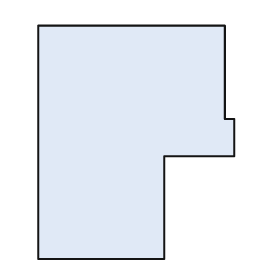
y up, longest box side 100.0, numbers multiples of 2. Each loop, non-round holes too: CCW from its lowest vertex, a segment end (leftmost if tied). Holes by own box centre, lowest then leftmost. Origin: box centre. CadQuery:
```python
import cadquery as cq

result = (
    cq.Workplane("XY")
    .moveTo(-42.0, -50.0)
    .lineTo(12.0, -50.0)
    .lineTo(12.0, -6.0)
    .lineTo(42.0, -6.0)
    .lineTo(42.0, 10.0)
    .lineTo(38.0, 10.0)
    .lineTo(38.0, 50.0)
    .lineTo(-42.0, 50.0)
    .close()
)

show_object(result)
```